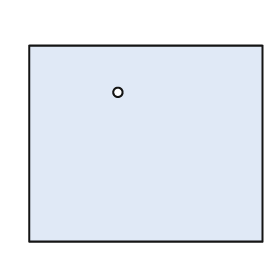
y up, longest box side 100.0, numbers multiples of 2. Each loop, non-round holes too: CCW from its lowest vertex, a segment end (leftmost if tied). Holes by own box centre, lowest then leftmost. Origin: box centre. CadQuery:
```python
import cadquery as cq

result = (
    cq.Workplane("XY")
    .moveTo(-50.0, -42.0)
    .lineTo(50.0, -42.0)
    .lineTo(50.0, 42.0)
    .lineTo(-50.0, 42.0)
    .close()
    .moveTo(-12.0, 22.0)
    .circle(2.0)
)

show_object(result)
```